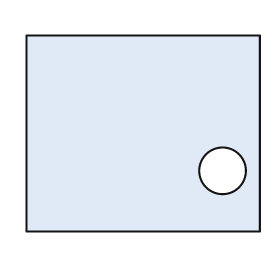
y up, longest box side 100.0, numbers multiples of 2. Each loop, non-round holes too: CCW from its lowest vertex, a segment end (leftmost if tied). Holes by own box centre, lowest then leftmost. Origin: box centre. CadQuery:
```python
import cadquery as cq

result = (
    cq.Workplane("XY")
    .moveTo(-50.0, -42.0)
    .lineTo(50.0, -42.0)
    .lineTo(50.0, 42.0)
    .lineTo(-50.0, 42.0)
    .close()
    .moveTo(34.0, -16.0)
    .circle(10.0)
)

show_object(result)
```